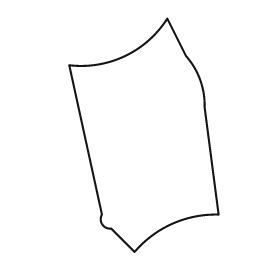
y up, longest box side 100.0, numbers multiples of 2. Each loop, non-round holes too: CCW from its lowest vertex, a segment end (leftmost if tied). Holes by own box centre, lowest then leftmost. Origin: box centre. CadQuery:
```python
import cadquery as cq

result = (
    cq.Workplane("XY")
    .moveTo(-4.0, -50.0)
    .threePointArc((12.0, -38.0), (32.0, -34.0))
    .lineTo(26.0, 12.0)
    .threePointArc((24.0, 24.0), (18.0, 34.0))
    .lineTo(10.0, 50.0)
    .threePointArc((-8.0, 34.0), (-32.0, 30.0))
    .lineTo(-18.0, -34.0)
    .threePointArc((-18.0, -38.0), (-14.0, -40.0))
    .close()
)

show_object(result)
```